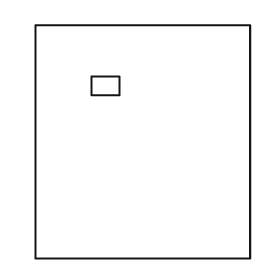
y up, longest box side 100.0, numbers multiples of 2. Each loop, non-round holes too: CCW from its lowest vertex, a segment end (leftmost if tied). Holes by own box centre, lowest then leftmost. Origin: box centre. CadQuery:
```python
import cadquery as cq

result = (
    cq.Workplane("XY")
    .moveTo(-46.0, -50.0)
    .lineTo(46.0, -50.0)
    .lineTo(46.0, 50.0)
    .lineTo(-46.0, 50.0)
    .close()
    .moveTo(-22.0, 20.0)
    .lineTo(-10.0, 20.0)
    .lineTo(-10.0, 28.0)
    .lineTo(-22.0, 28.0)
    .close()
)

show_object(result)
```